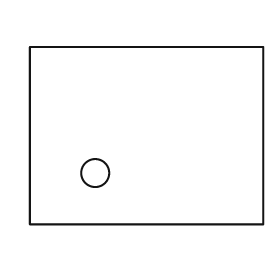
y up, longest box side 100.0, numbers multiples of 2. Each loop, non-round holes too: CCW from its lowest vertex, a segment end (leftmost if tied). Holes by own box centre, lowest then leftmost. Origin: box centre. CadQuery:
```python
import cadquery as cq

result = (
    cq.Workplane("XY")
    .moveTo(-50.0, -38.0)
    .lineTo(50.0, -38.0)
    .lineTo(50.0, 38.0)
    .lineTo(-50.0, 38.0)
    .close()
    .moveTo(-22.0, -16.0)
    .circle(6.0)
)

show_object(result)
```